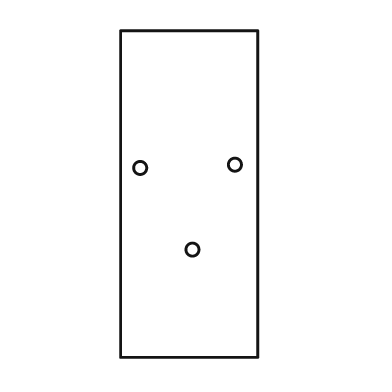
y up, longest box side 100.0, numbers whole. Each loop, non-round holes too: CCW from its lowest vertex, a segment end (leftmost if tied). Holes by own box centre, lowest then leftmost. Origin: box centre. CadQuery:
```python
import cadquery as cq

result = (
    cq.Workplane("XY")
    .moveTo(-21.0, -50.0)
    .lineTo(21.0, -50.0)
    .lineTo(21.0, 50.0)
    .lineTo(-21.0, 50.0)
    .close()
    .moveTo(1.0, -17.0)
    .circle(2.0)
    .moveTo(-15.0, 8.0)
    .circle(2.0)
    .moveTo(14.0, 9.0)
    .circle(2.0)
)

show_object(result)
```